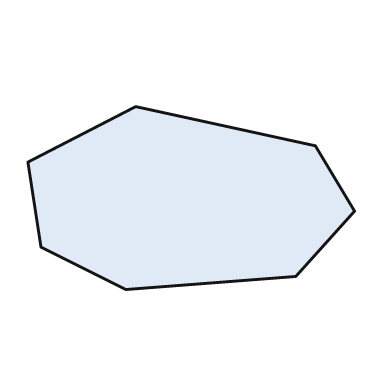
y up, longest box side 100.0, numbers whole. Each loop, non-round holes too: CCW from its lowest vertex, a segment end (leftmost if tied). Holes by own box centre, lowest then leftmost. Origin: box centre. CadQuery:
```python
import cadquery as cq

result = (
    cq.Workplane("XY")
    .moveTo(-20.0, -28.0)
    .lineTo(32.0, -24.0)
    .lineTo(50.0, -4.0)
    .lineTo(38.0, 16.0)
    .lineTo(-17.0, 28.0)
    .lineTo(-50.0, 11.0)
    .lineTo(-46.0, -15.0)
    .close()
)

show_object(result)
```